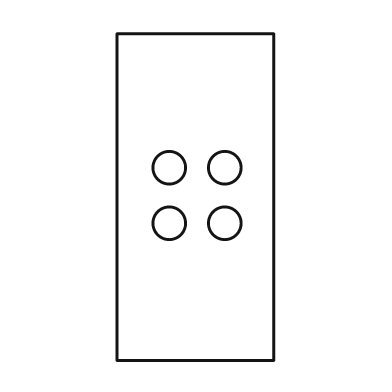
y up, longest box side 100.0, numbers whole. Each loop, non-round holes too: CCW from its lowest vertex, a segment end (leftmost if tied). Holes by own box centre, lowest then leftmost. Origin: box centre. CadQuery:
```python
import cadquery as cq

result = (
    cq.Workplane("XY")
    .moveTo(-24.0, -50.0)
    .lineTo(24.0, -50.0)
    .lineTo(24.0, 50.0)
    .lineTo(-24.0, 50.0)
    .close()
    .moveTo(-8.0, -8.0)
    .circle(5.0)
    .moveTo(9.0, -8.0)
    .circle(5.0)
    .moveTo(-8.0, 9.0)
    .circle(5.0)
    .moveTo(9.0, 9.0)
    .circle(5.0)
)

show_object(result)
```